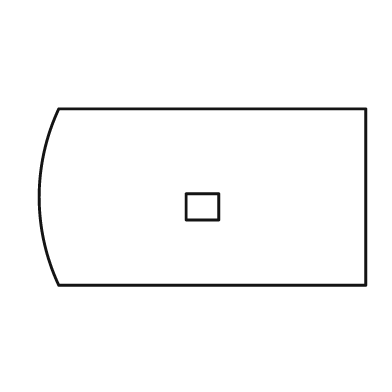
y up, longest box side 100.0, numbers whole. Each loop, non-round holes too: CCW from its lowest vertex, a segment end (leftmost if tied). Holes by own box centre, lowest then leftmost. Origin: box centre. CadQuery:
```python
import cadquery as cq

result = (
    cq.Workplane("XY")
    .moveTo(-44.0, -27.0)
    .lineTo(50.0, -27.0)
    .lineTo(50.0, 27.0)
    .lineTo(-44.0, 27.0)
    .threePointArc((-50.0, 0.0), (-44.0, -27.0))
    .close()
    .moveTo(-5.0, -7.0)
    .lineTo(5.0, -7.0)
    .lineTo(5.0, 1.0)
    .lineTo(-5.0, 1.0)
    .close()
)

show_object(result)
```